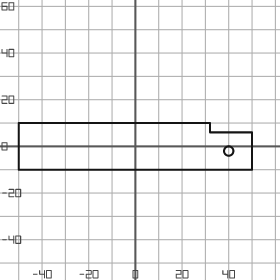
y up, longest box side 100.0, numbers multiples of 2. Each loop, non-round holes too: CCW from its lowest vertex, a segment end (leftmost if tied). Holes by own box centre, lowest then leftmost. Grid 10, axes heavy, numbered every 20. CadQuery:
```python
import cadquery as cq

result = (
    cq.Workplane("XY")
    .moveTo(-50.0, -10.0)
    .lineTo(50.0, -10.0)
    .lineTo(50.0, 6.0)
    .lineTo(32.0, 6.0)
    .lineTo(32.0, 10.0)
    .lineTo(-50.0, 10.0)
    .close()
    .moveTo(40.0, -2.0)
    .circle(2.0)
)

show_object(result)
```